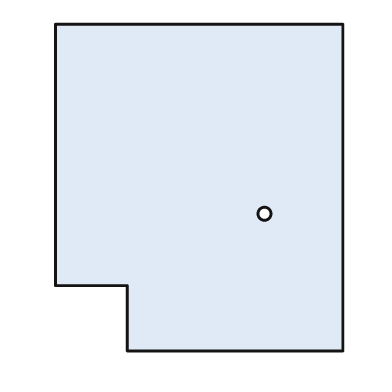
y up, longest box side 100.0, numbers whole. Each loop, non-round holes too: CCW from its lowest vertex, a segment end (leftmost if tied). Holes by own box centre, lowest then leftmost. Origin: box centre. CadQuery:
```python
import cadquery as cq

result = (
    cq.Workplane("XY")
    .moveTo(-22.0, -50.0)
    .lineTo(44.0, -50.0)
    .lineTo(44.0, 50.0)
    .lineTo(-44.0, 50.0)
    .lineTo(-44.0, -30.0)
    .lineTo(-22.0, -30.0)
    .close()
    .moveTo(20.0, -8.0)
    .circle(2.0)
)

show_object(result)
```